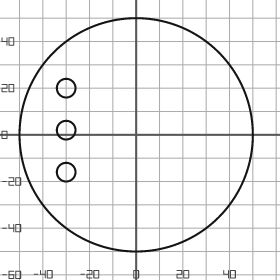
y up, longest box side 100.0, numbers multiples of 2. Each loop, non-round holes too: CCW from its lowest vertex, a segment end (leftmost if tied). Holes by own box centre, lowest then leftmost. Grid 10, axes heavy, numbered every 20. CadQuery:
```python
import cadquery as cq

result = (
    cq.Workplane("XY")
    .moveTo(0.0, 0.0)
    .circle(50.0)
    .moveTo(-30.0, -16.0)
    .circle(4.0)
    .moveTo(-30.0, 2.0)
    .circle(4.0)
    .moveTo(-30.0, 20.0)
    .circle(4.0)
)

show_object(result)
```